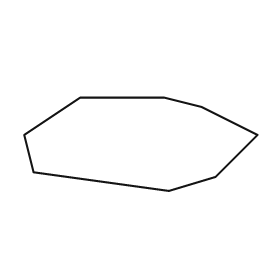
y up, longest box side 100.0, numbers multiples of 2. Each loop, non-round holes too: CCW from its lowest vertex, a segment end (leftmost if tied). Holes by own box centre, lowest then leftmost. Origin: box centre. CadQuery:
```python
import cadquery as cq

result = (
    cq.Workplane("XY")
    .moveTo(12.0, -20.0)
    .lineTo(32.0, -14.0)
    .lineTo(50.0, 4.0)
    .lineTo(26.0, 16.0)
    .lineTo(10.0, 20.0)
    .lineTo(-26.0, 20.0)
    .lineTo(-50.0, 4.0)
    .lineTo(-46.0, -12.0)
    .close()
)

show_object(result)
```